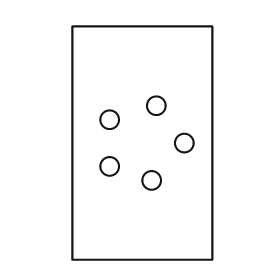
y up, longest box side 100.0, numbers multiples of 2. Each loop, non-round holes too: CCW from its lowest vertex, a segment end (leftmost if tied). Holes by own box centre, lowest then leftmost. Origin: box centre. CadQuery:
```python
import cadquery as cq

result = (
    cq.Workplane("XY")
    .moveTo(-30.0, -50.0)
    .lineTo(30.0, -50.0)
    .lineTo(30.0, 50.0)
    .lineTo(-30.0, 50.0)
    .close()
    .moveTo(4.0, -16.0)
    .circle(4.0)
    .moveTo(-14.0, -10.0)
    .circle(4.0)
    .moveTo(18.0, 0.0)
    .circle(4.0)
    .moveTo(-14.0, 10.0)
    .circle(4.0)
    .moveTo(6.0, 16.0)
    .circle(4.0)
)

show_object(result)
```